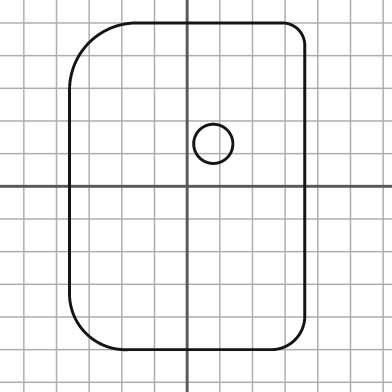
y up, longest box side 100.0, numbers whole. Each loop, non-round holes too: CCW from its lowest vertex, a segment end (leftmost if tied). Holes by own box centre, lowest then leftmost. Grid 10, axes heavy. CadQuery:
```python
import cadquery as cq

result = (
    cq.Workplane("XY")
    .moveTo(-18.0, -50.0)
    .lineTo(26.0, -50.0)
    .threePointArc((33.0, -47.0), (36.0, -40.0))
    .lineTo(36.0, 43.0)
    .threePointArc((34.0, 48.0), (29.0, 50.0))
    .lineTo(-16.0, 50.0)
    .threePointArc((-30.0, 44.0), (-36.0, 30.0))
    .lineTo(-36.0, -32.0)
    .threePointArc((-31.0, -45.0), (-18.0, -50.0))
    .close()
    .moveTo(8.0, 13.0)
    .circle(6.0)
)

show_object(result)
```